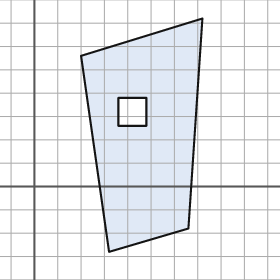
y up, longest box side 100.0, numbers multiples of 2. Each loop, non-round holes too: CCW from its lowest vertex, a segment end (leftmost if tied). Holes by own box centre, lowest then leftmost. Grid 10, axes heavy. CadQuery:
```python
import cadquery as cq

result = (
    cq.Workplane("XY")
    .moveTo(32.0, -28.0)
    .lineTo(66.0, -18.0)
    .lineTo(72.0, 72.0)
    .lineTo(20.0, 56.0)
    .close()
    .moveTo(36.0, 26.0)
    .lineTo(48.0, 26.0)
    .lineTo(48.0, 38.0)
    .lineTo(36.0, 38.0)
    .close()
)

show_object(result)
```